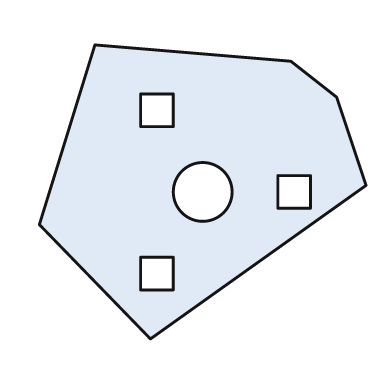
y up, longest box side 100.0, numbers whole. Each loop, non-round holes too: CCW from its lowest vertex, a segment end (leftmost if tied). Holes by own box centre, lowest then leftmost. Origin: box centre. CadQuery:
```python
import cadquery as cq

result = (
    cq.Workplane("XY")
    .moveTo(-16.0, -45.0)
    .lineTo(50.0, 2.0)
    .lineTo(41.0, 29.0)
    .lineTo(27.0, 40.0)
    .lineTo(-33.0, 45.0)
    .lineTo(-50.0, -10.0)
    .close()
    .moveTo(-19.0, -30.0)
    .lineTo(-9.0, -30.0)
    .lineTo(-9.0, -20.0)
    .lineTo(-19.0, -20.0)
    .close()
    .moveTo(0.0, 0.0)
    .circle(9.0)
    .moveTo(23.0, -5.0)
    .lineTo(33.0, -5.0)
    .lineTo(33.0, 5.0)
    .lineTo(23.0, 5.0)
    .close()
    .moveTo(-19.0, 20.0)
    .lineTo(-9.0, 20.0)
    .lineTo(-9.0, 30.0)
    .lineTo(-19.0, 30.0)
    .close()
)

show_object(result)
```